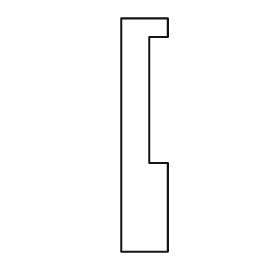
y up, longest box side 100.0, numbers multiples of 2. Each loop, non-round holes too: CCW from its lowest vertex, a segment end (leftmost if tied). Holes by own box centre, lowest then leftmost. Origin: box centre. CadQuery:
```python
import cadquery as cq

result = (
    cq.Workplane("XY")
    .moveTo(-10.0, -50.0)
    .lineTo(10.0, -50.0)
    .lineTo(10.0, -12.0)
    .lineTo(2.0, -12.0)
    .lineTo(2.0, 42.0)
    .lineTo(10.0, 42.0)
    .lineTo(10.0, 50.0)
    .lineTo(-10.0, 50.0)
    .close()
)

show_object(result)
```